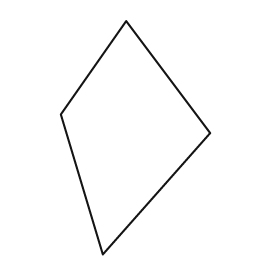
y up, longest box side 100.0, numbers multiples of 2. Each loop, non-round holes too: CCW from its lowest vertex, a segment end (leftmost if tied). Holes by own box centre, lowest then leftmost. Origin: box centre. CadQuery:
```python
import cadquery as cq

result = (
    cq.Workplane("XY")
    .moveTo(-14.0, -50.0)
    .lineTo(32.0, 2.0)
    .lineTo(-4.0, 50.0)
    .lineTo(-32.0, 10.0)
    .close()
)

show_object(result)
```